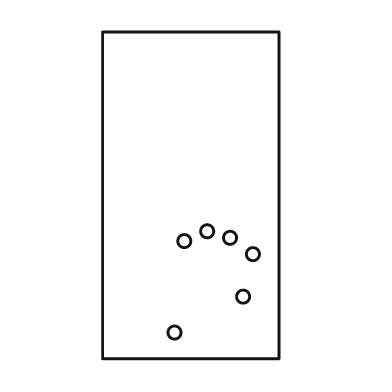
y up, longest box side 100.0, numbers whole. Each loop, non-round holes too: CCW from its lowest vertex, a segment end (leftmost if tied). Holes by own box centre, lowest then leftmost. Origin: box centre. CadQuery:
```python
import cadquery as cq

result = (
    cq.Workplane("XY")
    .moveTo(-27.0, -50.0)
    .lineTo(27.0, -50.0)
    .lineTo(27.0, 50.0)
    .lineTo(-27.0, 50.0)
    .close()
    .moveTo(-5.0, -42.0)
    .circle(2.0)
    .moveTo(16.0, -31.0)
    .circle(2.0)
    .moveTo(19.0, -18.0)
    .circle(2.0)
    .moveTo(-2.0, -14.0)
    .circle(2.0)
    .moveTo(12.0, -13.0)
    .circle(2.0)
    .moveTo(5.0, -11.0)
    .circle(2.0)
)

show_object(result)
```